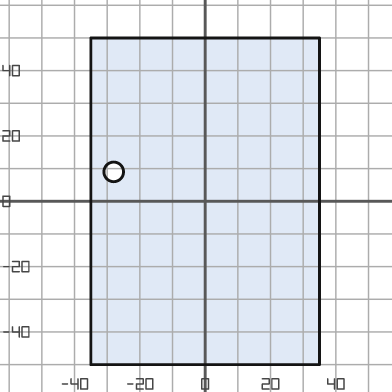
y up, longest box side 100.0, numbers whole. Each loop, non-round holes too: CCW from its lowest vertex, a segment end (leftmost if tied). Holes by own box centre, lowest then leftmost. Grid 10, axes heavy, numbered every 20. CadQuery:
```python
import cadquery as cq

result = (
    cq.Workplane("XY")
    .moveTo(-35.0, -50.0)
    .lineTo(35.0, -50.0)
    .lineTo(35.0, 50.0)
    .lineTo(-35.0, 50.0)
    .close()
    .moveTo(-28.0, 9.0)
    .circle(3.0)
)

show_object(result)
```